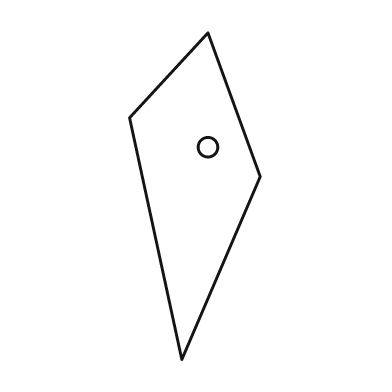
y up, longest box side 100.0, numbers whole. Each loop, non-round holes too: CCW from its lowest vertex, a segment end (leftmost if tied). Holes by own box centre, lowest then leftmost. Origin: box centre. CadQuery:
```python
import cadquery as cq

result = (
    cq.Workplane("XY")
    .moveTo(-4.0, -50.0)
    .lineTo(20.0, 6.0)
    .lineTo(4.0, 50.0)
    .lineTo(-20.0, 24.0)
    .close()
    .moveTo(4.0, 15.0)
    .circle(3.0)
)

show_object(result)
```